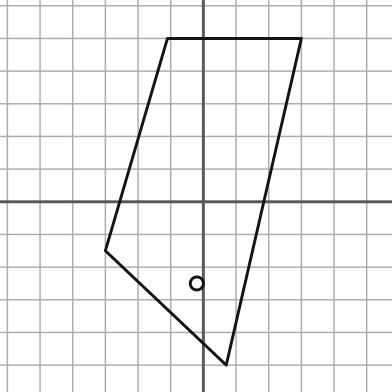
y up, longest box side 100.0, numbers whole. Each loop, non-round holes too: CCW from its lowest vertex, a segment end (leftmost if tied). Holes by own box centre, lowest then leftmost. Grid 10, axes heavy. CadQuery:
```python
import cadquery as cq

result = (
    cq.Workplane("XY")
    .moveTo(7.0, -50.0)
    .lineTo(30.0, 50.0)
    .lineTo(-11.0, 50.0)
    .lineTo(-30.0, -15.0)
    .close()
    .moveTo(-2.0, -25.0)
    .circle(2.0)
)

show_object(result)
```